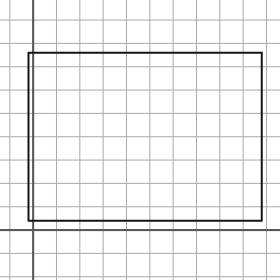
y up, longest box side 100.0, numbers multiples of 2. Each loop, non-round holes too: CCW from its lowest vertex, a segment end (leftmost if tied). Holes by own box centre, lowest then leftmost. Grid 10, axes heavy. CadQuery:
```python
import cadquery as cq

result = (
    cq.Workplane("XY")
    .moveTo(-2.0, 4.0)
    .lineTo(98.0, 4.0)
    .lineTo(98.0, 76.0)
    .lineTo(-2.0, 76.0)
    .close()
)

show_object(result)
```